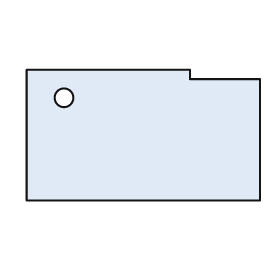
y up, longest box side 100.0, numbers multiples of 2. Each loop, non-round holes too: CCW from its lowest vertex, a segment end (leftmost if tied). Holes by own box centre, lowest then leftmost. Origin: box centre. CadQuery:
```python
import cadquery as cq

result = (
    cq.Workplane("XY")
    .moveTo(-50.0, -28.0)
    .lineTo(50.0, -28.0)
    .lineTo(50.0, 24.0)
    .lineTo(20.0, 24.0)
    .lineTo(20.0, 28.0)
    .lineTo(-50.0, 28.0)
    .close()
    .moveTo(-34.0, 16.0)
    .circle(4.0)
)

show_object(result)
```